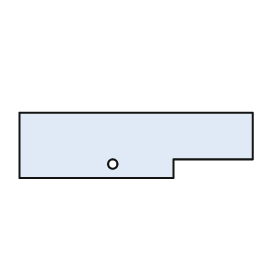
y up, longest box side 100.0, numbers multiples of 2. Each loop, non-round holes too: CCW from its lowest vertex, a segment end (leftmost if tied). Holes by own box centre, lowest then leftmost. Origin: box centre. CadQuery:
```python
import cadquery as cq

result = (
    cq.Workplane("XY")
    .moveTo(-50.0, -14.0)
    .lineTo(16.0, -14.0)
    .lineTo(16.0, -6.0)
    .lineTo(50.0, -6.0)
    .lineTo(50.0, 14.0)
    .lineTo(-50.0, 14.0)
    .close()
    .moveTo(-10.0, -8.0)
    .circle(2.0)
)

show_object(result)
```